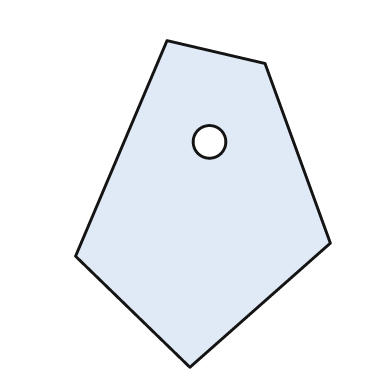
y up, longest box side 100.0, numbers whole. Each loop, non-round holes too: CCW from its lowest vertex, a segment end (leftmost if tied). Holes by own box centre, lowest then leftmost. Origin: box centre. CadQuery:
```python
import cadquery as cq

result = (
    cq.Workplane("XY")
    .moveTo(-4.0, -50.0)
    .lineTo(39.0, -12.0)
    .lineTo(19.0, 43.0)
    .lineTo(-11.0, 50.0)
    .lineTo(-39.0, -16.0)
    .close()
    .moveTo(2.0, 19.0)
    .circle(5.0)
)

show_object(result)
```